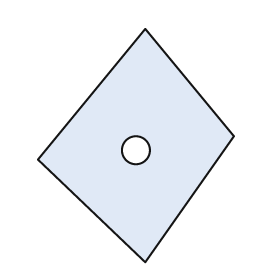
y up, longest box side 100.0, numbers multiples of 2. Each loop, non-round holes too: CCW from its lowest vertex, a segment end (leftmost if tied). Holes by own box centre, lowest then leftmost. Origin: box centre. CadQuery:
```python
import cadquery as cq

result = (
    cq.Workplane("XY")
    .moveTo(4.0, -50.0)
    .lineTo(42.0, 4.0)
    .lineTo(4.0, 50.0)
    .lineTo(-42.0, -6.0)
    .close()
    .moveTo(0.0, -2.0)
    .circle(6.0)
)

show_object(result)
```